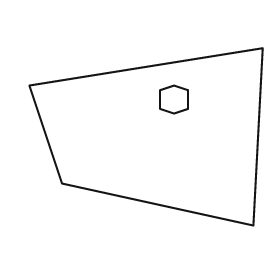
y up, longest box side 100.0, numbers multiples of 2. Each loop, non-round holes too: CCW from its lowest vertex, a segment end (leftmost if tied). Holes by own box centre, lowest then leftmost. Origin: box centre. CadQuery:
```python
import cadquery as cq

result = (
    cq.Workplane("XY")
    .moveTo(46.0, -38.0)
    .lineTo(50.0, 38.0)
    .lineTo(-50.0, 22.0)
    .lineTo(-36.0, -20.0)
    .close()
    .moveTo(12.0, 10.0)
    .lineTo(18.0, 12.0)
    .lineTo(18.0, 20.0)
    .lineTo(12.0, 22.0)
    .lineTo(6.0, 20.0)
    .lineTo(6.0, 12.0)
    .close()
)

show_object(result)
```